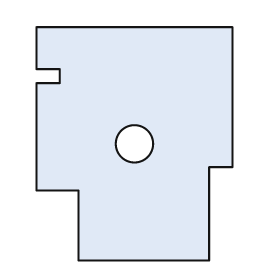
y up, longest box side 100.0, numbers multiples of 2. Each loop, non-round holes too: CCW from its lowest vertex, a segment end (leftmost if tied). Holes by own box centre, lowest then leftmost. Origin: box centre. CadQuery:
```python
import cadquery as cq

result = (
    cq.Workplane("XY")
    .moveTo(-24.0, -50.0)
    .lineTo(32.0, -50.0)
    .lineTo(32.0, -10.0)
    .lineTo(42.0, -10.0)
    .lineTo(42.0, 50.0)
    .lineTo(-42.0, 50.0)
    .lineTo(-42.0, 32.0)
    .lineTo(-32.0, 32.0)
    .lineTo(-32.0, 26.0)
    .lineTo(-42.0, 26.0)
    .lineTo(-42.0, -20.0)
    .lineTo(-24.0, -20.0)
    .close()
    .moveTo(0.0, 0.0)
    .circle(8.0)
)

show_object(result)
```